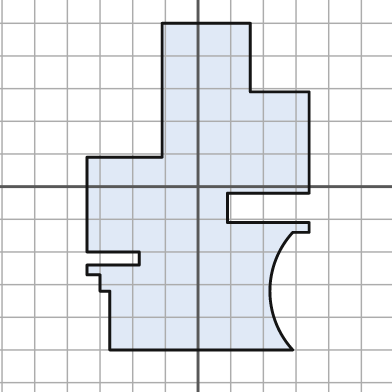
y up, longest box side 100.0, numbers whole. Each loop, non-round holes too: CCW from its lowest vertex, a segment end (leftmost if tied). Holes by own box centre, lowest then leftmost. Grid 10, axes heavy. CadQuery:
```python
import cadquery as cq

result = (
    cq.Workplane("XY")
    .moveTo(-27.0, -50.0)
    .lineTo(29.0, -50.0)
    .threePointArc((22.0, -32.0), (29.0, -14.0))
    .lineTo(34.0, -14.0)
    .lineTo(34.0, -11.0)
    .lineTo(9.0, -11.0)
    .lineTo(9.0, -2.0)
    .lineTo(34.0, -2.0)
    .lineTo(34.0, 29.0)
    .lineTo(16.0, 29.0)
    .lineTo(16.0, 50.0)
    .lineTo(-11.0, 50.0)
    .lineTo(-11.0, 9.0)
    .lineTo(-34.0, 9.0)
    .lineTo(-34.0, -20.0)
    .lineTo(-18.0, -20.0)
    .lineTo(-18.0, -24.0)
    .lineTo(-34.0, -24.0)
    .lineTo(-34.0, -27.0)
    .lineTo(-30.0, -27.0)
    .lineTo(-30.0, -32.0)
    .lineTo(-27.0, -32.0)
    .close()
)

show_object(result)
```